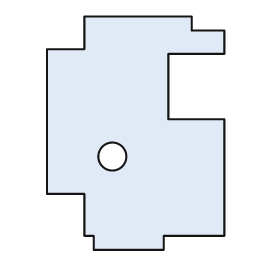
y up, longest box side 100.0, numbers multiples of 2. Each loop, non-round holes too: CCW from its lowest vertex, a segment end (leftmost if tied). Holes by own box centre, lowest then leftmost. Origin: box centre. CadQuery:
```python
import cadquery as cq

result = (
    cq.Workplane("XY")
    .moveTo(-18.0, -50.0)
    .lineTo(12.0, -50.0)
    .lineTo(12.0, -44.0)
    .lineTo(38.0, -44.0)
    .lineTo(38.0, 6.0)
    .lineTo(14.0, 6.0)
    .lineTo(14.0, 34.0)
    .lineTo(38.0, 34.0)
    .lineTo(38.0, 44.0)
    .lineTo(24.0, 44.0)
    .lineTo(24.0, 50.0)
    .lineTo(-22.0, 50.0)
    .lineTo(-22.0, 36.0)
    .lineTo(-38.0, 36.0)
    .lineTo(-38.0, -26.0)
    .lineTo(-22.0, -26.0)
    .lineTo(-22.0, -44.0)
    .lineTo(-18.0, -44.0)
    .close()
    .moveTo(-10.0, -10.0)
    .circle(6.0)
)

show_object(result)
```